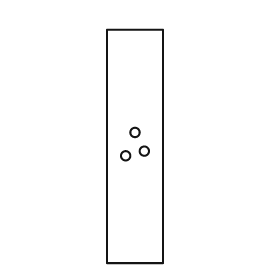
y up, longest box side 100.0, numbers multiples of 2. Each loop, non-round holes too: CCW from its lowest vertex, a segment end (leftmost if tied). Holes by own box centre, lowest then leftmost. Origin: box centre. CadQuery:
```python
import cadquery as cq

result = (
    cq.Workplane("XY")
    .moveTo(-12.0, -50.0)
    .lineTo(12.0, -50.0)
    .lineTo(12.0, 50.0)
    .lineTo(-12.0, 50.0)
    .close()
    .moveTo(-4.0, -4.0)
    .circle(2.0)
    .moveTo(4.0, -2.0)
    .circle(2.0)
    .moveTo(0.0, 6.0)
    .circle(2.0)
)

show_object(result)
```